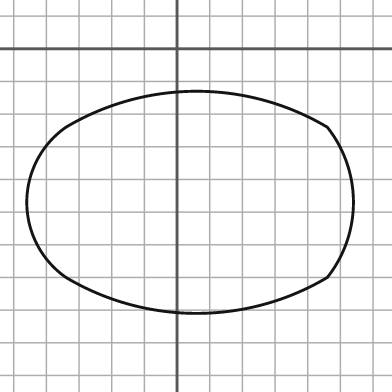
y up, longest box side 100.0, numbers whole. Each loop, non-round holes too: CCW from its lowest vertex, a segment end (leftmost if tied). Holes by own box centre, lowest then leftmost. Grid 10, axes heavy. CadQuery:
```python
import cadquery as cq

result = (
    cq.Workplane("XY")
    .moveTo(-34.0, -70.0)
    .threePointArc((6.0, -81.0), (46.0, -70.0))
    .threePointArc((54.0, -47.0), (46.0, -24.0))
    .threePointArc((6.0, -13.0), (-34.0, -24.0))
    .threePointArc((-46.0, -47.0), (-34.0, -70.0))
    .close()
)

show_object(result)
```